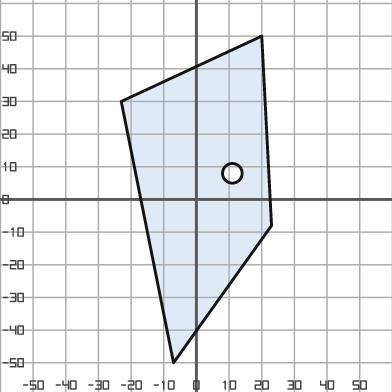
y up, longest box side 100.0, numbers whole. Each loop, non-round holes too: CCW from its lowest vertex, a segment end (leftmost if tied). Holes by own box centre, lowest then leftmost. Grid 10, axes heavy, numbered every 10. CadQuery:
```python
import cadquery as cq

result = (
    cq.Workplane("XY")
    .moveTo(-7.0, -50.0)
    .lineTo(23.0, -8.0)
    .lineTo(20.0, 50.0)
    .lineTo(-23.0, 30.0)
    .close()
    .moveTo(11.0, 8.0)
    .circle(3.0)
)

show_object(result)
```